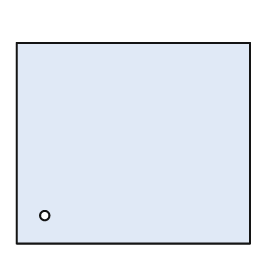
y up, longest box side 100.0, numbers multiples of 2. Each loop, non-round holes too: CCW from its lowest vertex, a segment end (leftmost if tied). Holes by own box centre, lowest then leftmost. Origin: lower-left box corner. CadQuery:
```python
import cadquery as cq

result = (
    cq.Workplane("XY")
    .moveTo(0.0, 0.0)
    .lineTo(100.0, 0.0)
    .lineTo(100.0, 86.0)
    .lineTo(0.0, 86.0)
    .close()
    .moveTo(12.0, 12.0)
    .circle(2.0)
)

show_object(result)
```